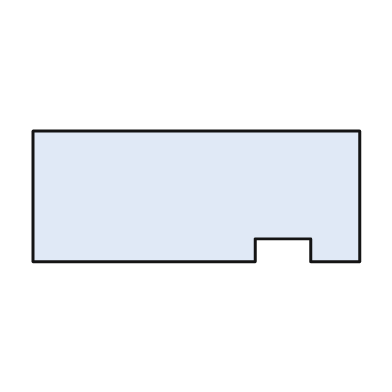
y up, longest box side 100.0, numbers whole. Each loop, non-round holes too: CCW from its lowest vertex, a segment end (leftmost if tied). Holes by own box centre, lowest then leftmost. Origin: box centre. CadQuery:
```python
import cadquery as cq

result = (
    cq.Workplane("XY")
    .moveTo(-50.0, -20.0)
    .lineTo(18.0, -20.0)
    .lineTo(18.0, -13.0)
    .lineTo(35.0, -13.0)
    .lineTo(35.0, -20.0)
    .lineTo(50.0, -20.0)
    .lineTo(50.0, 20.0)
    .lineTo(-50.0, 20.0)
    .close()
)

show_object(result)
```